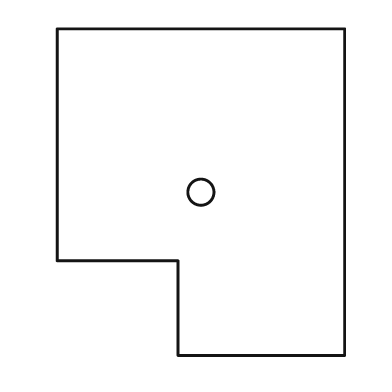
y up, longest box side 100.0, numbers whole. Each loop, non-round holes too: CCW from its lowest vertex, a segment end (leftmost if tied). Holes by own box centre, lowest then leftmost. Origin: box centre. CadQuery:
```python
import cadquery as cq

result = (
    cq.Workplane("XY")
    .moveTo(-7.0, -50.0)
    .lineTo(44.0, -50.0)
    .lineTo(44.0, 50.0)
    .lineTo(-44.0, 50.0)
    .lineTo(-44.0, -21.0)
    .lineTo(-7.0, -21.0)
    .close()
    .moveTo(0.0, 0.0)
    .circle(4.0)
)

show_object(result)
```